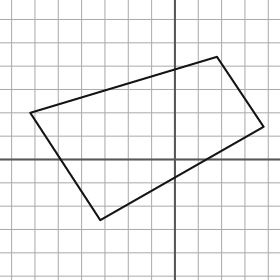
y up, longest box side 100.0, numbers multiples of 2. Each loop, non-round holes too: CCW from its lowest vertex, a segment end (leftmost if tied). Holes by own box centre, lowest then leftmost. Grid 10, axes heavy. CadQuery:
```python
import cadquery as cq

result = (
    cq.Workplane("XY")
    .moveTo(-32.0, -26.0)
    .lineTo(38.0, 14.0)
    .lineTo(18.0, 44.0)
    .lineTo(-62.0, 20.0)
    .close()
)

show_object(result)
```